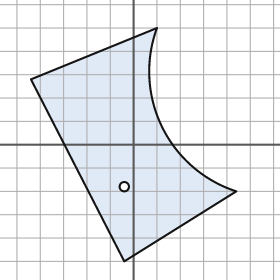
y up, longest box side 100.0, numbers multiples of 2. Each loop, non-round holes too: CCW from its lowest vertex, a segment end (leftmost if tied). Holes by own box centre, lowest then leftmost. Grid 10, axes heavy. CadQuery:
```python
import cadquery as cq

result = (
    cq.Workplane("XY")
    .moveTo(-4.0, -50.0)
    .lineTo(44.0, -20.0)
    .threePointArc((12.0, 8.0), (10.0, 50.0))
    .lineTo(-44.0, 28.0)
    .close()
    .moveTo(-4.0, -18.0)
    .circle(2.0)
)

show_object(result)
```